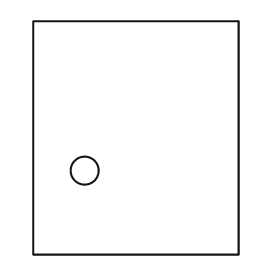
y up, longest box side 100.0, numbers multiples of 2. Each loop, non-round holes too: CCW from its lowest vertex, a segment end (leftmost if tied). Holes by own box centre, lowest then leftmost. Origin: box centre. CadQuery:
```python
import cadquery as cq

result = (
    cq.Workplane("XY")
    .moveTo(-44.0, -50.0)
    .lineTo(44.0, -50.0)
    .lineTo(44.0, 50.0)
    .lineTo(-44.0, 50.0)
    .close()
    .moveTo(-22.0, -14.0)
    .circle(6.0)
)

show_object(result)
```